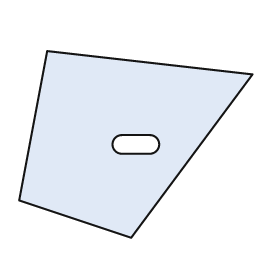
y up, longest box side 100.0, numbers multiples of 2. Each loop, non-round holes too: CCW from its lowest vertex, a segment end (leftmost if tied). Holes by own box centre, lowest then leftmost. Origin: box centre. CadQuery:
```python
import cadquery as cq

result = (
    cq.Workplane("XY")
    .moveTo(-2.0, -40.0)
    .lineTo(50.0, 30.0)
    .lineTo(-38.0, 40.0)
    .lineTo(-50.0, -24.0)
    .close()
    .moveTo(-6.0, -4.0)
    .lineTo(6.0, -4.0)
    .threePointArc((10.0, 0.0), (6.0, 4.0))
    .lineTo(-6.0, 4.0)
    .threePointArc((-10.0, 0.0), (-6.0, -4.0))
    .close()
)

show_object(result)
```